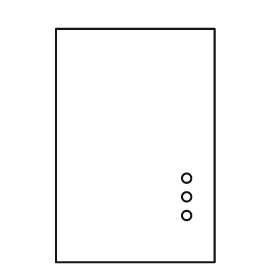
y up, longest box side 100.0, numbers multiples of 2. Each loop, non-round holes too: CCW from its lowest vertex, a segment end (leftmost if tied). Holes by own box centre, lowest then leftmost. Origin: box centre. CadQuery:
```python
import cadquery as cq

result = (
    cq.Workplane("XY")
    .moveTo(-34.0, -50.0)
    .lineTo(34.0, -50.0)
    .lineTo(34.0, 50.0)
    .lineTo(-34.0, 50.0)
    .close()
    .moveTo(22.0, -30.0)
    .circle(2.0)
    .moveTo(22.0, -22.0)
    .circle(2.0)
    .moveTo(22.0, -14.0)
    .circle(2.0)
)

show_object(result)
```